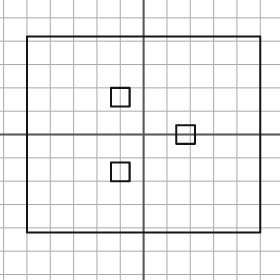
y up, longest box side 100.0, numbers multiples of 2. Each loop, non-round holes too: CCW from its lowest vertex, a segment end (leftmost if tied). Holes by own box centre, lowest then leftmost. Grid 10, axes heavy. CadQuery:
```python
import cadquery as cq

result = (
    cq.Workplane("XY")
    .moveTo(-50.0, -42.0)
    .lineTo(50.0, -42.0)
    .lineTo(50.0, 42.0)
    .lineTo(-50.0, 42.0)
    .close()
    .moveTo(-14.0, -20.0)
    .lineTo(-6.0, -20.0)
    .lineTo(-6.0, -12.0)
    .lineTo(-14.0, -12.0)
    .close()
    .moveTo(14.0, -4.0)
    .lineTo(22.0, -4.0)
    .lineTo(22.0, 4.0)
    .lineTo(14.0, 4.0)
    .close()
    .moveTo(-14.0, 12.0)
    .lineTo(-6.0, 12.0)
    .lineTo(-6.0, 20.0)
    .lineTo(-14.0, 20.0)
    .close()
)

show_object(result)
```